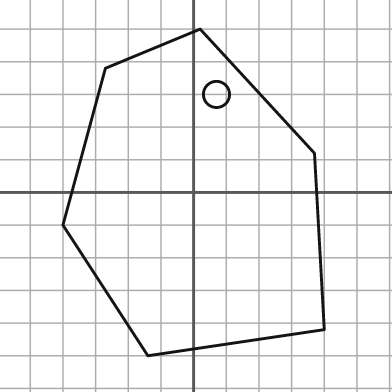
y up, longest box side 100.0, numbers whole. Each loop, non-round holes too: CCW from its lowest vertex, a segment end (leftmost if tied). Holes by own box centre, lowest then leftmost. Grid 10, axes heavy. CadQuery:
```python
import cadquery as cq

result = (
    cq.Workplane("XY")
    .moveTo(-14.0, -50.0)
    .lineTo(40.0, -42.0)
    .lineTo(37.0, 12.0)
    .lineTo(2.0, 50.0)
    .lineTo(-27.0, 38.0)
    .lineTo(-40.0, -10.0)
    .close()
    .moveTo(7.0, 30.0)
    .circle(4.0)
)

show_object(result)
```